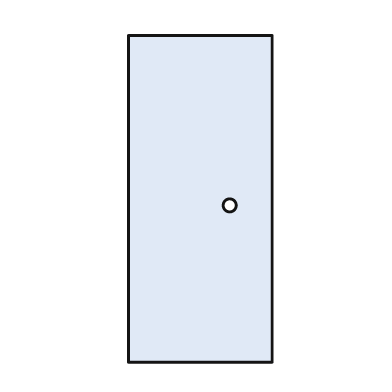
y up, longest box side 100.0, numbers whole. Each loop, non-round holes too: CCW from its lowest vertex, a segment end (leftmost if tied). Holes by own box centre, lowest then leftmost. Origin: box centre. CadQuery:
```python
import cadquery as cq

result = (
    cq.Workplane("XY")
    .moveTo(-22.0, -50.0)
    .lineTo(22.0, -50.0)
    .lineTo(22.0, 50.0)
    .lineTo(-22.0, 50.0)
    .close()
    .moveTo(9.0, -2.0)
    .circle(2.0)
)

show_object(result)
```